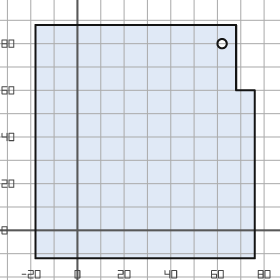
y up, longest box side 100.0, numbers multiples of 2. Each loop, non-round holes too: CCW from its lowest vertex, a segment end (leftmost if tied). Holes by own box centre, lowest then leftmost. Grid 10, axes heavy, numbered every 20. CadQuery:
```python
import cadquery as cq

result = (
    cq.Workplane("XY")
    .moveTo(-18.0, -12.0)
    .lineTo(76.0, -12.0)
    .lineTo(76.0, 60.0)
    .lineTo(68.0, 60.0)
    .lineTo(68.0, 88.0)
    .lineTo(-18.0, 88.0)
    .close()
    .moveTo(62.0, 80.0)
    .circle(2.0)
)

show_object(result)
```